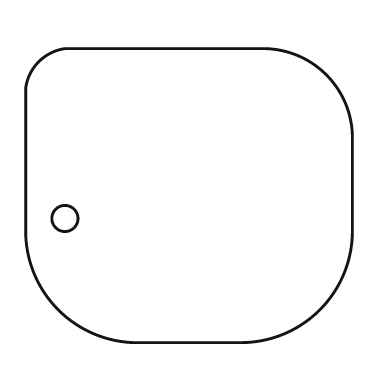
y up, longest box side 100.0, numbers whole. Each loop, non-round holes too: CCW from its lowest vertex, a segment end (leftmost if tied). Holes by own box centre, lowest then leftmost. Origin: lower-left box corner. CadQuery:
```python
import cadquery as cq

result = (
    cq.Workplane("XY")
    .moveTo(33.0, 0.0)
    .lineTo(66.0, 0.0)
    .threePointArc((90.0, 10.0), (100.0, 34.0))
    .lineTo(100.0, 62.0)
    .threePointArc((92.0, 82.0), (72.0, 90.0))
    .lineTo(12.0, 90.0)
    .threePointArc((4.0, 86.0), (0.0, 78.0))
    .lineTo(0.0, 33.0)
    .threePointArc((10.0, 10.0), (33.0, 0.0))
    .close()
    .moveTo(12.0, 38.0)
    .circle(4.0)
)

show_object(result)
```